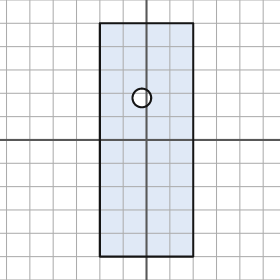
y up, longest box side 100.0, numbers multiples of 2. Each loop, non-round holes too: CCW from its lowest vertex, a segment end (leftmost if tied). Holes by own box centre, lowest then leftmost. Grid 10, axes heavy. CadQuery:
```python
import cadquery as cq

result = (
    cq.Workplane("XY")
    .moveTo(-20.0, -50.0)
    .lineTo(20.0, -50.0)
    .lineTo(20.0, 50.0)
    .lineTo(-20.0, 50.0)
    .close()
    .moveTo(-2.0, 18.0)
    .circle(4.0)
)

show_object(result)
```